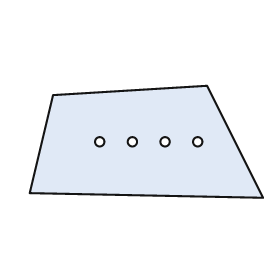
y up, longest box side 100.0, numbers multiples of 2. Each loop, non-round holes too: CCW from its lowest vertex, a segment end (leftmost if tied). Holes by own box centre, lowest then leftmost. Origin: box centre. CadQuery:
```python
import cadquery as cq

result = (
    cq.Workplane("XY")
    .moveTo(50.0, -24.0)
    .lineTo(26.0, 24.0)
    .lineTo(-40.0, 20.0)
    .lineTo(-50.0, -22.0)
    .close()
    .moveTo(-20.0, 0.0)
    .circle(2.0)
    .moveTo(-6.0, 0.0)
    .circle(2.0)
    .moveTo(8.0, 0.0)
    .circle(2.0)
    .moveTo(22.0, 0.0)
    .circle(2.0)
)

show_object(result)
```